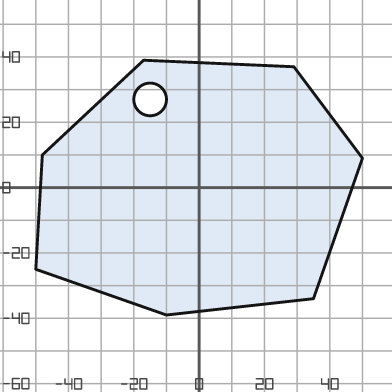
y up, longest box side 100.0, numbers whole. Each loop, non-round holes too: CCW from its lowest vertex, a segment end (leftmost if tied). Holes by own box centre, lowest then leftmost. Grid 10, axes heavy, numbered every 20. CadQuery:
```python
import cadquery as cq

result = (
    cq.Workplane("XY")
    .moveTo(-10.0, -39.0)
    .lineTo(35.0, -34.0)
    .lineTo(50.0, 9.0)
    .lineTo(29.0, 37.0)
    .lineTo(-17.0, 39.0)
    .lineTo(-48.0, 10.0)
    .lineTo(-50.0, -25.0)
    .close()
    .moveTo(-15.0, 27.0)
    .circle(5.0)
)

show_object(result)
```